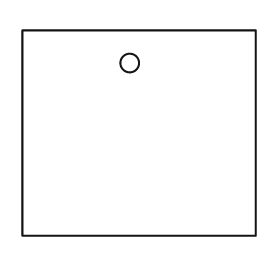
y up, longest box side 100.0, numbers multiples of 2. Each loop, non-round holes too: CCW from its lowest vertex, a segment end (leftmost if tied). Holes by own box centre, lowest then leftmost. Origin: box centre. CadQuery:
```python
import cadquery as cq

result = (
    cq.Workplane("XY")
    .moveTo(-50.0, -44.0)
    .lineTo(50.0, -44.0)
    .lineTo(50.0, 44.0)
    .lineTo(-50.0, 44.0)
    .close()
    .moveTo(-4.0, 30.0)
    .circle(4.0)
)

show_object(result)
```